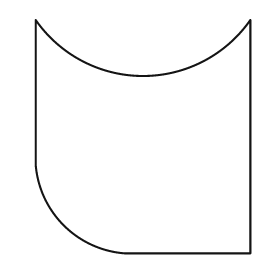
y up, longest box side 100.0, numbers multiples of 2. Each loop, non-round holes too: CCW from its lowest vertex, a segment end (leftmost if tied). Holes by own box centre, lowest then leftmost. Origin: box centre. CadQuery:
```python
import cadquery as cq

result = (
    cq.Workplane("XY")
    .moveTo(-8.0, -50.0)
    .lineTo(46.0, -50.0)
    .lineTo(46.0, 50.0)
    .threePointArc((0.0, 26.0), (-46.0, 50.0))
    .lineTo(-46.0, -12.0)
    .threePointArc((-34.0, -38.0), (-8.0, -50.0))
    .close()
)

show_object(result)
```